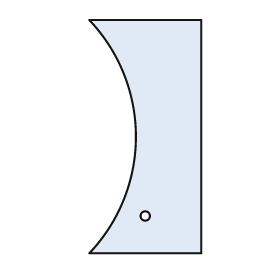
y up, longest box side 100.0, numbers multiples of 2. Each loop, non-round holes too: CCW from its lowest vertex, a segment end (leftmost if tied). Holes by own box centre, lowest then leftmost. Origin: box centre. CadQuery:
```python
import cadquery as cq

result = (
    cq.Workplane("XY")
    .moveTo(-24.0, -50.0)
    .lineTo(24.0, -50.0)
    .lineTo(24.0, 50.0)
    .lineTo(-24.0, 50.0)
    .threePointArc((-4.0, 0.0), (-24.0, -50.0))
    .close()
    .moveTo(0.0, -34.0)
    .circle(2.0)
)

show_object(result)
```